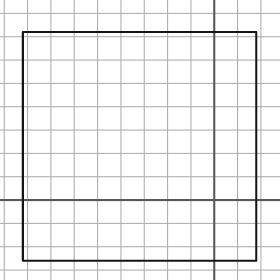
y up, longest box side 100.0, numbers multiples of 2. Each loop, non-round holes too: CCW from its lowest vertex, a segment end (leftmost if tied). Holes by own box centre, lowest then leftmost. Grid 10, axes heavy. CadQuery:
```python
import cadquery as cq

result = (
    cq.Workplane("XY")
    .moveTo(-82.0, -26.0)
    .lineTo(18.0, -26.0)
    .lineTo(18.0, 72.0)
    .lineTo(-82.0, 72.0)
    .close()
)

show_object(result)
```